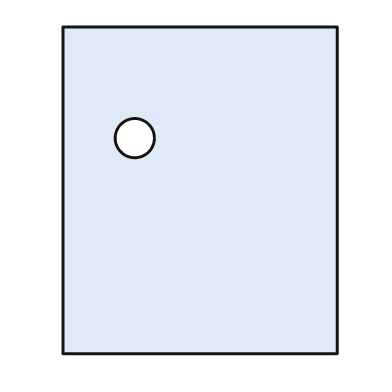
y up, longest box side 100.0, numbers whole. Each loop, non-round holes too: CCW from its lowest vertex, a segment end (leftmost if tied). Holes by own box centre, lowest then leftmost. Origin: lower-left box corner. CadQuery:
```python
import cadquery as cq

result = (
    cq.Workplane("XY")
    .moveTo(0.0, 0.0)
    .lineTo(84.0, 0.0)
    .lineTo(84.0, 100.0)
    .lineTo(0.0, 100.0)
    .close()
    .moveTo(22.0, 66.0)
    .circle(6.0)
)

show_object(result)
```